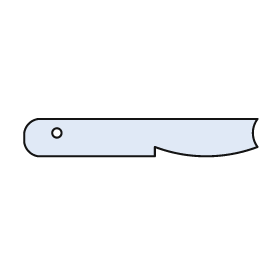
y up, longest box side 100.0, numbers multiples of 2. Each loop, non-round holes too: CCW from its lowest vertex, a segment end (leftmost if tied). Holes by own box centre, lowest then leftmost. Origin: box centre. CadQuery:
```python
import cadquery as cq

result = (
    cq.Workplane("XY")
    .moveTo(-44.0, -8.0)
    .lineTo(6.0, -8.0)
    .lineTo(6.0, -4.0)
    .threePointArc((28.0, -8.0), (50.0, -4.0))
    .threePointArc((48.0, 2.0), (50.0, 8.0))
    .lineTo(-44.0, 8.0)
    .threePointArc((-48.0, 6.0), (-50.0, 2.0))
    .lineTo(-50.0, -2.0)
    .threePointArc((-48.0, -6.0), (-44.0, -8.0))
    .close()
    .moveTo(-36.0, 2.0)
    .circle(2.0)
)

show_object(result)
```